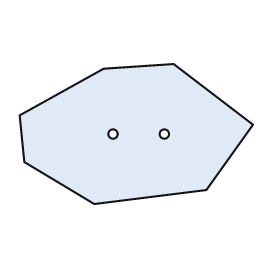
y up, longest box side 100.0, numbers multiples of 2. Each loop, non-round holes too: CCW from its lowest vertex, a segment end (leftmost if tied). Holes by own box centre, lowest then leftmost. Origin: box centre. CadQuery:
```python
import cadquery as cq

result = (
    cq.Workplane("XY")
    .moveTo(-18.0, -30.0)
    .lineTo(30.0, -24.0)
    .lineTo(50.0, 4.0)
    .lineTo(16.0, 30.0)
    .lineTo(-14.0, 28.0)
    .lineTo(-50.0, 8.0)
    .lineTo(-48.0, -12.0)
    .close()
    .moveTo(-10.0, 0.0)
    .circle(2.0)
    .moveTo(12.0, 0.0)
    .circle(2.0)
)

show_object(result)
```